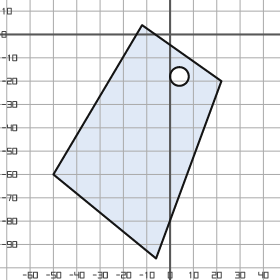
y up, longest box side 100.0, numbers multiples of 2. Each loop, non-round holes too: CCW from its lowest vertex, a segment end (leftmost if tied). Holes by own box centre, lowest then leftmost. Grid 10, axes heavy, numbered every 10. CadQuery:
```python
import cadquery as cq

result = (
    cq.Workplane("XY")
    .moveTo(-6.0, -96.0)
    .lineTo(22.0, -20.0)
    .lineTo(-12.0, 4.0)
    .lineTo(-50.0, -60.0)
    .close()
    .moveTo(4.0, -18.0)
    .circle(4.0)
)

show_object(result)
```